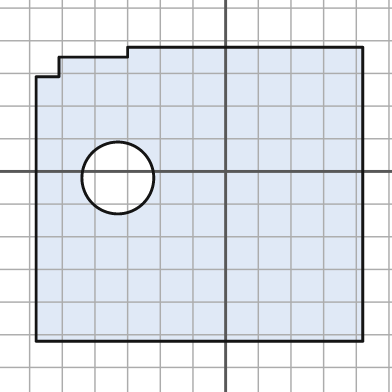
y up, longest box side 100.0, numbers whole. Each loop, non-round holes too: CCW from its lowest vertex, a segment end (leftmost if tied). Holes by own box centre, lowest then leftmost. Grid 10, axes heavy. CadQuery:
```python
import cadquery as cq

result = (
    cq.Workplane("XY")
    .moveTo(-58.0, -52.0)
    .lineTo(42.0, -52.0)
    .lineTo(42.0, 38.0)
    .lineTo(-30.0, 38.0)
    .lineTo(-30.0, 35.0)
    .lineTo(-51.0, 35.0)
    .lineTo(-51.0, 29.0)
    .lineTo(-58.0, 29.0)
    .close()
    .moveTo(-33.0, -2.0)
    .circle(11.0)
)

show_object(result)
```